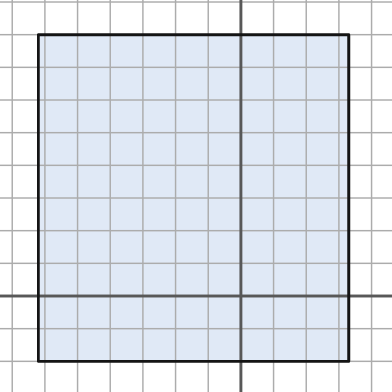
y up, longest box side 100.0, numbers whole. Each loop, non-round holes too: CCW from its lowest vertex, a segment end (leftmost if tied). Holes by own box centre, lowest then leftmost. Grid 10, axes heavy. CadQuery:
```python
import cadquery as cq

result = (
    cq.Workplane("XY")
    .moveTo(-62.0, -20.0)
    .lineTo(33.0, -20.0)
    .lineTo(33.0, 80.0)
    .lineTo(-62.0, 80.0)
    .close()
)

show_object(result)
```